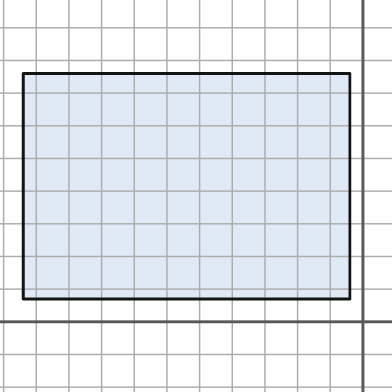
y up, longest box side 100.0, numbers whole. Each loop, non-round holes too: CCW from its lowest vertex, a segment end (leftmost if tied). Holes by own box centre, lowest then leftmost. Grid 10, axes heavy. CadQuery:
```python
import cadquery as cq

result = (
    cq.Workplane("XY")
    .moveTo(-104.0, 7.0)
    .lineTo(-4.0, 7.0)
    .lineTo(-4.0, 76.0)
    .lineTo(-104.0, 76.0)
    .close()
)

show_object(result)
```